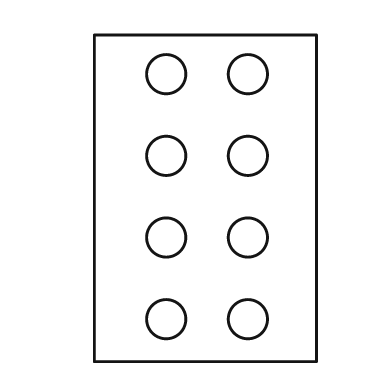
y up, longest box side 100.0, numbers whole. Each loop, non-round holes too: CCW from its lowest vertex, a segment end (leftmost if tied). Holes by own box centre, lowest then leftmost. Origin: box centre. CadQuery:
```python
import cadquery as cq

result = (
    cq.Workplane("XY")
    .moveTo(-34.0, -50.0)
    .lineTo(34.0, -50.0)
    .lineTo(34.0, 50.0)
    .lineTo(-34.0, 50.0)
    .close()
    .moveTo(-12.0, -37.0)
    .circle(6.0)
    .moveTo(13.0, -37.0)
    .circle(6.0)
    .moveTo(-12.0, -12.0)
    .circle(6.0)
    .moveTo(13.0, -12.0)
    .circle(6.0)
    .moveTo(-12.0, 13.0)
    .circle(6.0)
    .moveTo(13.0, 13.0)
    .circle(6.0)
    .moveTo(-12.0, 38.0)
    .circle(6.0)
    .moveTo(13.0, 38.0)
    .circle(6.0)
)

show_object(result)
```